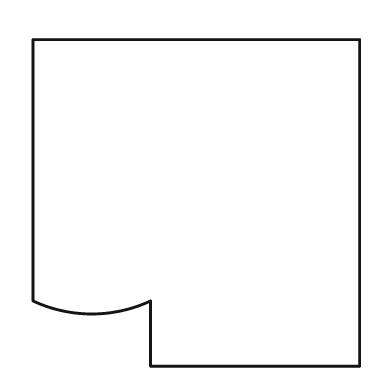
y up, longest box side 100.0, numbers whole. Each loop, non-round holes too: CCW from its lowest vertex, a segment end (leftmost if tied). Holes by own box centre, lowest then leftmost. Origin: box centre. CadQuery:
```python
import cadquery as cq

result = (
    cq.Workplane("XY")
    .moveTo(-14.0, -50.0)
    .lineTo(50.0, -50.0)
    .lineTo(50.0, 50.0)
    .lineTo(-50.0, 50.0)
    .lineTo(-50.0, -30.0)
    .threePointArc((-32.0, -34.0), (-14.0, -30.0))
    .close()
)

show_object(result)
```